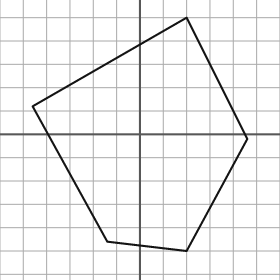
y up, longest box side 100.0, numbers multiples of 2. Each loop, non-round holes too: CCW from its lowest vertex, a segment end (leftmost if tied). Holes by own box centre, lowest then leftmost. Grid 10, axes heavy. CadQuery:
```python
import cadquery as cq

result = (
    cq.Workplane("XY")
    .moveTo(20.0, -50.0)
    .lineTo(46.0, -2.0)
    .lineTo(20.0, 50.0)
    .lineTo(-46.0, 12.0)
    .lineTo(-14.0, -46.0)
    .close()
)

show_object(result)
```